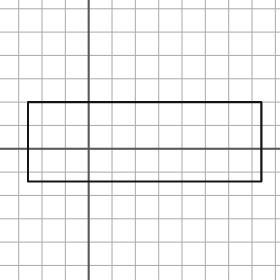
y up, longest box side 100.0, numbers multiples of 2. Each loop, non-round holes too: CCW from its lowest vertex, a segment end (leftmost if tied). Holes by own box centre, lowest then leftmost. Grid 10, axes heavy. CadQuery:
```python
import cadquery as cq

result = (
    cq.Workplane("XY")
    .moveTo(-26.0, -14.0)
    .lineTo(74.0, -14.0)
    .lineTo(74.0, 20.0)
    .lineTo(-26.0, 20.0)
    .close()
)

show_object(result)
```